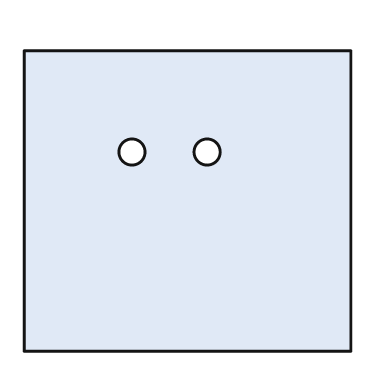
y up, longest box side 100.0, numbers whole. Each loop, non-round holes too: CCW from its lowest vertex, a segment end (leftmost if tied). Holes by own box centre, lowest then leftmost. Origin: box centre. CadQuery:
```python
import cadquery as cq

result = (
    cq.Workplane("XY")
    .moveTo(-50.0, -46.0)
    .lineTo(50.0, -46.0)
    .lineTo(50.0, 46.0)
    .lineTo(-50.0, 46.0)
    .close()
    .moveTo(-17.0, 15.0)
    .circle(4.0)
    .moveTo(6.0, 15.0)
    .circle(4.0)
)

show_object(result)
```